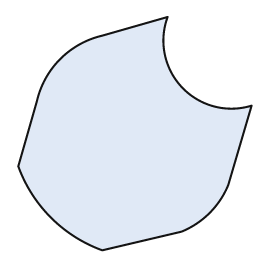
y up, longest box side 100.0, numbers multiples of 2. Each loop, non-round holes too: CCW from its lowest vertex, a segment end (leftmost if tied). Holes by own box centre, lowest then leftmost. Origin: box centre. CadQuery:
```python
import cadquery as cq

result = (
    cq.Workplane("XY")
    .moveTo(-14.0, -50.0)
    .lineTo(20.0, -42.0)
    .threePointArc((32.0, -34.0), (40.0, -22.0))
    .lineTo(50.0, 12.0)
    .threePointArc((20.0, 20.0), (14.0, 50.0))
    .lineTo(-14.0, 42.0)
    .threePointArc((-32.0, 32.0), (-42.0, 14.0))
    .lineTo(-50.0, -14.0)
    .threePointArc((-36.0, -36.0), (-14.0, -50.0))
    .close()
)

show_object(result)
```